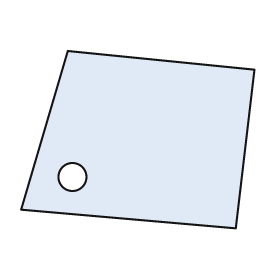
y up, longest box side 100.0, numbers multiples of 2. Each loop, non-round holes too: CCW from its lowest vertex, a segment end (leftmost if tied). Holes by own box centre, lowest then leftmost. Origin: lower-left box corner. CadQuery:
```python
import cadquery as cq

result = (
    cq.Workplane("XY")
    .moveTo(92.0, 0.0)
    .lineTo(100.0, 68.0)
    .lineTo(20.0, 76.0)
    .lineTo(0.0, 8.0)
    .close()
    .moveTo(22.0, 22.0)
    .circle(6.0)
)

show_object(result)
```